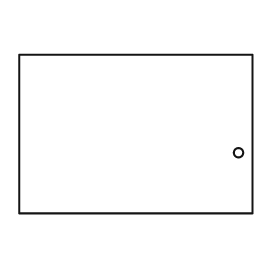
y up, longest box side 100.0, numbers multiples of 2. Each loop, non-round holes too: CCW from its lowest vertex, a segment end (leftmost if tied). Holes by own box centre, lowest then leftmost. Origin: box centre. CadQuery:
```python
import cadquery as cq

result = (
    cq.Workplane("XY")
    .moveTo(-50.0, -34.0)
    .lineTo(50.0, -34.0)
    .lineTo(50.0, 34.0)
    .lineTo(-50.0, 34.0)
    .close()
    .moveTo(44.0, -8.0)
    .circle(2.0)
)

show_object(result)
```